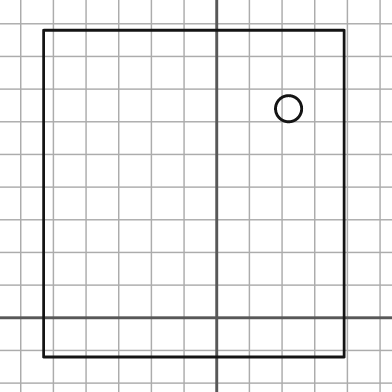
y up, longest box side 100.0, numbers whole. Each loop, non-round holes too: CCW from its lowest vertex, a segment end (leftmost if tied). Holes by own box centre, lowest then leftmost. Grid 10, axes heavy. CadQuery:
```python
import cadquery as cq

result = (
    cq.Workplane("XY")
    .moveTo(-53.0, -12.0)
    .lineTo(39.0, -12.0)
    .lineTo(39.0, 88.0)
    .lineTo(-53.0, 88.0)
    .close()
    .moveTo(22.0, 64.0)
    .circle(4.0)
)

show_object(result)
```